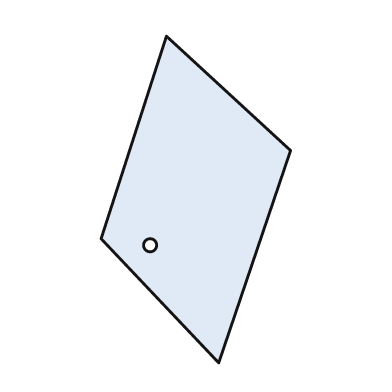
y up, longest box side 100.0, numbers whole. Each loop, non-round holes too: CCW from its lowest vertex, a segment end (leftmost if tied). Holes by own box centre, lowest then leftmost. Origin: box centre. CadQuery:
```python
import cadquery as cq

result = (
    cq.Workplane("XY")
    .moveTo(7.0, -50.0)
    .lineTo(29.0, 15.0)
    .lineTo(-9.0, 50.0)
    .lineTo(-29.0, -12.0)
    .close()
    .moveTo(-14.0, -14.0)
    .circle(2.0)
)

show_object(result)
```